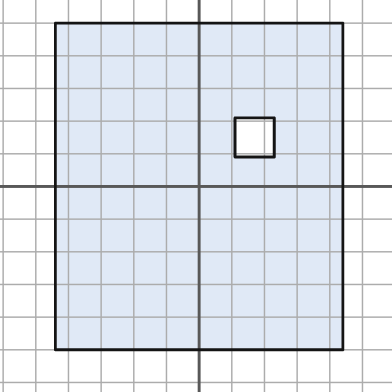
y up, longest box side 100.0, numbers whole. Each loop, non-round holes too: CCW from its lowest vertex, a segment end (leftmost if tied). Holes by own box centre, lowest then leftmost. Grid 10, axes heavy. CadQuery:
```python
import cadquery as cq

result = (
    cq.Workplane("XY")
    .moveTo(-44.0, -50.0)
    .lineTo(44.0, -50.0)
    .lineTo(44.0, 50.0)
    .lineTo(-44.0, 50.0)
    .close()
    .moveTo(11.0, 9.0)
    .lineTo(23.0, 9.0)
    .lineTo(23.0, 21.0)
    .lineTo(11.0, 21.0)
    .close()
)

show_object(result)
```